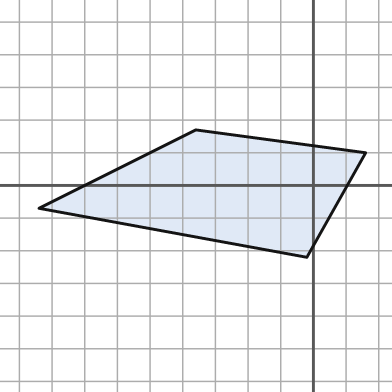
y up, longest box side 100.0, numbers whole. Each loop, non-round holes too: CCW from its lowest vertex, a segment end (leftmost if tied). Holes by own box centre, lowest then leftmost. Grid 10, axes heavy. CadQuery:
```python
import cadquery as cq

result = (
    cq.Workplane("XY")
    .moveTo(-2.0, -22.0)
    .lineTo(16.0, 10.0)
    .lineTo(-36.0, 17.0)
    .lineTo(-84.0, -7.0)
    .close()
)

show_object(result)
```